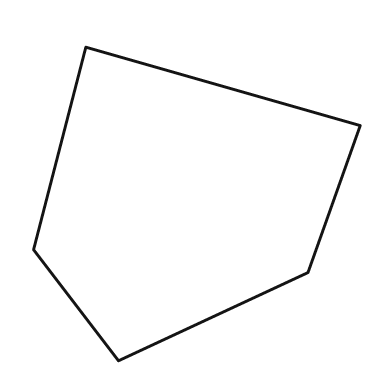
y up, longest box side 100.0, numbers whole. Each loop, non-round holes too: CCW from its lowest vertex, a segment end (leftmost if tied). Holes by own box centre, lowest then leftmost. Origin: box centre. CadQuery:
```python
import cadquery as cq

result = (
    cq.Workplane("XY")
    .moveTo(-24.0, -48.0)
    .lineTo(34.0, -21.0)
    .lineTo(50.0, 24.0)
    .lineTo(-34.0, 48.0)
    .lineTo(-50.0, -14.0)
    .close()
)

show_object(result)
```